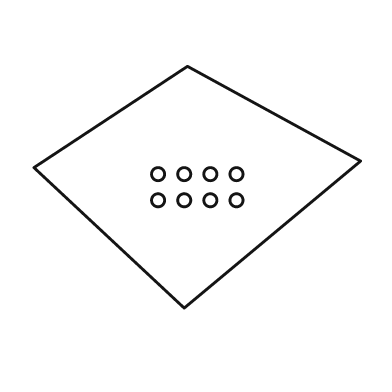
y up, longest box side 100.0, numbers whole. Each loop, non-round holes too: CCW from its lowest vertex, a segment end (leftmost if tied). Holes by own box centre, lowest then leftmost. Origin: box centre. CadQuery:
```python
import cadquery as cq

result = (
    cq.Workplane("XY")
    .moveTo(-4.0, -37.0)
    .lineTo(50.0, 8.0)
    .lineTo(-3.0, 37.0)
    .lineTo(-50.0, 6.0)
    .close()
    .moveTo(-12.0, -4.0)
    .circle(2.0)
    .moveTo(-4.0, -4.0)
    .circle(2.0)
    .moveTo(4.0, -4.0)
    .circle(2.0)
    .moveTo(12.0, -4.0)
    .circle(2.0)
    .moveTo(-12.0, 4.0)
    .circle(2.0)
    .moveTo(-4.0, 4.0)
    .circle(2.0)
    .moveTo(4.0, 4.0)
    .circle(2.0)
    .moveTo(12.0, 4.0)
    .circle(2.0)
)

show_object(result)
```